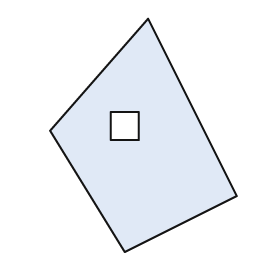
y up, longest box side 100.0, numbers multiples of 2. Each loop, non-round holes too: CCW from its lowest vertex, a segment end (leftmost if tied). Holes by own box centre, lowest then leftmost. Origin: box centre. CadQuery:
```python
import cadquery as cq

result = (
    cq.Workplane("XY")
    .moveTo(-8.0, -50.0)
    .lineTo(40.0, -26.0)
    .lineTo(2.0, 50.0)
    .lineTo(-40.0, 2.0)
    .close()
    .moveTo(-14.0, -2.0)
    .lineTo(-2.0, -2.0)
    .lineTo(-2.0, 10.0)
    .lineTo(-14.0, 10.0)
    .close()
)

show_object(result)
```